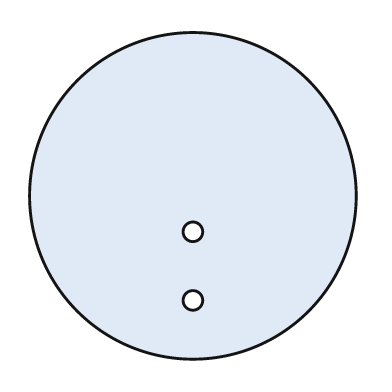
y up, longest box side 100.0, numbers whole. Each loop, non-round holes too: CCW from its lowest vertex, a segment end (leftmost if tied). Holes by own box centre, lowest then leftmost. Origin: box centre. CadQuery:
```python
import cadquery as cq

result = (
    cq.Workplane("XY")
    .moveTo(0.0, 0.0)
    .circle(50.0)
    .moveTo(0.0, -32.0)
    .circle(3.0)
    .moveTo(0.0, -11.0)
    .circle(3.0)
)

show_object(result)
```